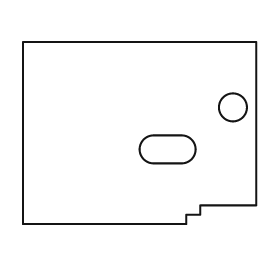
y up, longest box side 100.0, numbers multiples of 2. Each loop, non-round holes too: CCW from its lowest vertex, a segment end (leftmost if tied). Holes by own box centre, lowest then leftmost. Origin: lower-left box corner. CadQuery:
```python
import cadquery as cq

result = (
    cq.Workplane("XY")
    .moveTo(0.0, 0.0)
    .lineTo(70.0, 0.0)
    .lineTo(70.0, 4.0)
    .lineTo(76.0, 4.0)
    .lineTo(76.0, 8.0)
    .lineTo(100.0, 8.0)
    .lineTo(100.0, 78.0)
    .lineTo(0.0, 78.0)
    .close()
    .moveTo(56.0, 26.0)
    .lineTo(68.0, 26.0)
    .threePointArc((74.0, 32.0), (68.0, 38.0))
    .lineTo(56.0, 38.0)
    .threePointArc((50.0, 32.0), (56.0, 26.0))
    .close()
    .moveTo(90.0, 50.0)
    .circle(6.0)
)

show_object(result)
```